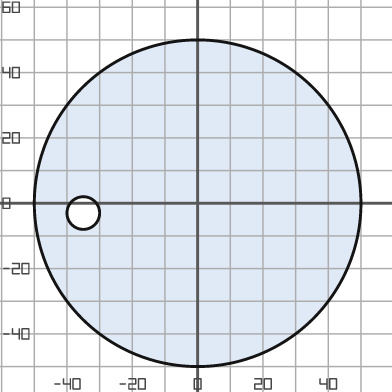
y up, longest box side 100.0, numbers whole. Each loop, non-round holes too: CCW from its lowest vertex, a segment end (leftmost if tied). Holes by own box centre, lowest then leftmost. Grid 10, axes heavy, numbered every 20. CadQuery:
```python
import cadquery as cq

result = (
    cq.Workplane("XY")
    .moveTo(0.0, 0.0)
    .circle(50.0)
    .moveTo(-35.0, -3.0)
    .circle(5.0)
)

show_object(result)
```